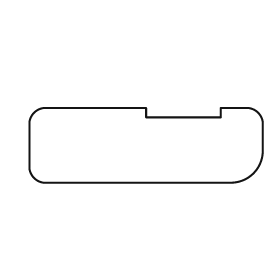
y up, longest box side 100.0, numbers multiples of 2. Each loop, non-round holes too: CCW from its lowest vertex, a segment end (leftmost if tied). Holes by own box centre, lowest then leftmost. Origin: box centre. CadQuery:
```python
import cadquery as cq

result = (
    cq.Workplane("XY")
    .moveTo(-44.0, -16.0)
    .lineTo(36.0, -16.0)
    .threePointArc((46.0, -12.0), (50.0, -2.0))
    .lineTo(50.0, 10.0)
    .threePointArc((48.0, 14.0), (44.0, 16.0))
    .lineTo(32.0, 16.0)
    .lineTo(32.0, 12.0)
    .lineTo(0.0, 12.0)
    .lineTo(0.0, 16.0)
    .lineTo(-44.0, 16.0)
    .threePointArc((-48.0, 14.0), (-50.0, 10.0))
    .lineTo(-50.0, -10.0)
    .threePointArc((-48.0, -14.0), (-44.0, -16.0))
    .close()
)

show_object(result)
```